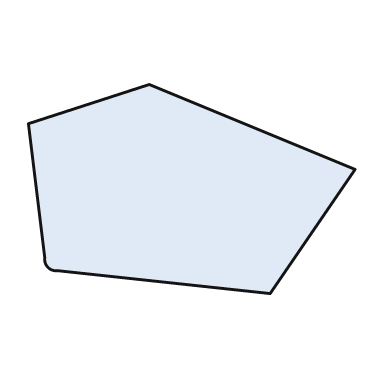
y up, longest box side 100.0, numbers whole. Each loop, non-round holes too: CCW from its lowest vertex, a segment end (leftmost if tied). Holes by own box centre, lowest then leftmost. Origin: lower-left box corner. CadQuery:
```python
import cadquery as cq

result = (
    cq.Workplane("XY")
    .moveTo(74.0, 0.0)
    .lineTo(100.0, 38.0)
    .lineTo(37.0, 64.0)
    .lineTo(0.0, 52.0)
    .lineTo(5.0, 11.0)
    .threePointArc((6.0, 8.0), (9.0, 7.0))
    .close()
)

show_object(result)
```